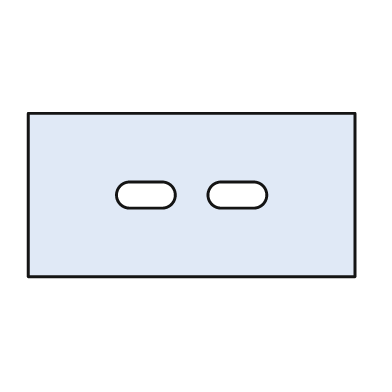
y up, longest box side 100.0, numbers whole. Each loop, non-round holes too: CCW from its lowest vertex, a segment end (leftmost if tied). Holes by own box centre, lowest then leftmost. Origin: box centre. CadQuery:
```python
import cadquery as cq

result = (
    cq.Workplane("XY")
    .moveTo(-50.0, -25.0)
    .lineTo(50.0, -25.0)
    .lineTo(50.0, 25.0)
    .lineTo(-50.0, 25.0)
    .close()
    .moveTo(-19.0, -4.0)
    .lineTo(-9.0, -4.0)
    .threePointArc((-5.0, 0.0), (-9.0, 4.0))
    .lineTo(-19.0, 4.0)
    .threePointArc((-23.0, 0.0), (-19.0, -4.0))
    .close()
    .moveTo(9.0, -4.0)
    .lineTo(19.0, -4.0)
    .threePointArc((23.0, 0.0), (19.0, 4.0))
    .lineTo(9.0, 4.0)
    .threePointArc((5.0, 0.0), (9.0, -4.0))
    .close()
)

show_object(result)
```